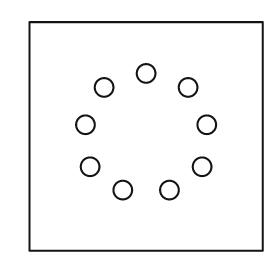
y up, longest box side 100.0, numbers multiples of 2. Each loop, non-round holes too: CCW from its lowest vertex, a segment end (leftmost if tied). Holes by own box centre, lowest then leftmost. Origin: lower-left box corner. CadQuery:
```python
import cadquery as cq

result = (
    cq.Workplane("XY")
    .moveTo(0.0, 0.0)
    .lineTo(100.0, 0.0)
    .lineTo(100.0, 98.0)
    .lineTo(0.0, 98.0)
    .close()
    .moveTo(40.0, 26.0)
    .circle(4.0)
    .moveTo(60.0, 26.0)
    .circle(4.0)
    .moveTo(26.0, 36.0)
    .circle(4.0)
    .moveTo(74.0, 36.0)
    .circle(4.0)
    .moveTo(24.0, 54.0)
    .circle(4.0)
    .moveTo(76.0, 54.0)
    .circle(4.0)
    .moveTo(32.0, 70.0)
    .circle(4.0)
    .moveTo(68.0, 70.0)
    .circle(4.0)
    .moveTo(50.0, 76.0)
    .circle(4.0)
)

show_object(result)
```